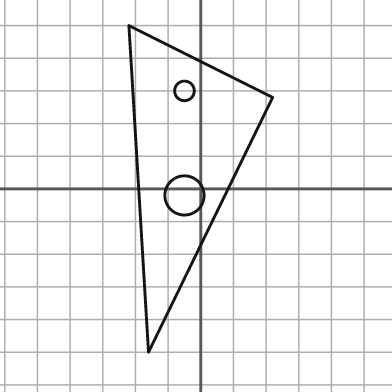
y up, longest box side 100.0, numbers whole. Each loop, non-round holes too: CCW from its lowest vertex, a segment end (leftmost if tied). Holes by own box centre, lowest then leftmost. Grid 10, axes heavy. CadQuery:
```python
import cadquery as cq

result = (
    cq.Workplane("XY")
    .moveTo(-16.0, -50.0)
    .lineTo(22.0, 28.0)
    .lineTo(-22.0, 50.0)
    .close()
    .moveTo(-5.0, -2.0)
    .circle(6.0)
    .moveTo(-5.0, 30.0)
    .circle(3.0)
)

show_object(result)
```